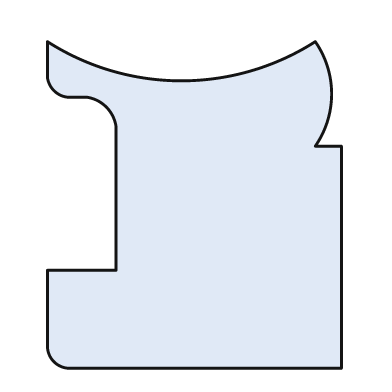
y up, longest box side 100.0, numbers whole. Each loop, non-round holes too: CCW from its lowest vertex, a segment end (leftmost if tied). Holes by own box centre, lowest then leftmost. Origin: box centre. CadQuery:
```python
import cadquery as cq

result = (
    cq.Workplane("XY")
    .moveTo(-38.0, -50.0)
    .lineTo(45.0, -50.0)
    .lineTo(45.0, 18.0)
    .lineTo(37.0, 18.0)
    .threePointArc((42.0, 34.0), (37.0, 50.0))
    .threePointArc((-4.0, 38.0), (-45.0, 50.0))
    .lineTo(-45.0, 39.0)
    .threePointArc((-43.0, 35.0), (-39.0, 33.0))
    .lineTo(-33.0, 33.0)
    .threePointArc((-27.0, 30.0), (-24.0, 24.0))
    .lineTo(-24.0, -20.0)
    .lineTo(-45.0, -20.0)
    .lineTo(-45.0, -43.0)
    .threePointArc((-43.0, -48.0), (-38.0, -50.0))
    .close()
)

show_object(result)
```